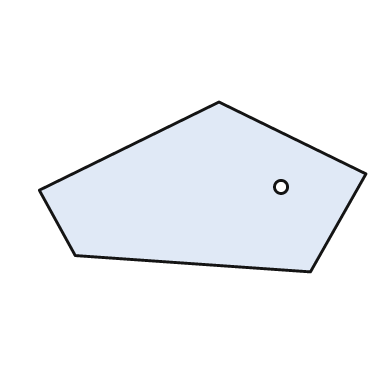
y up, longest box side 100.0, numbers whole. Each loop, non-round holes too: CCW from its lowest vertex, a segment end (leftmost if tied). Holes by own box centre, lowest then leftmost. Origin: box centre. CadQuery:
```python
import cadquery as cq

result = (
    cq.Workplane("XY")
    .moveTo(33.0, -26.0)
    .lineTo(50.0, 4.0)
    .lineTo(5.0, 26.0)
    .lineTo(-50.0, -1.0)
    .lineTo(-39.0, -21.0)
    .close()
    .moveTo(24.0, 0.0)
    .circle(2.0)
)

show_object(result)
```